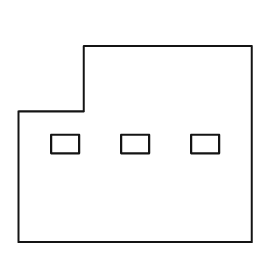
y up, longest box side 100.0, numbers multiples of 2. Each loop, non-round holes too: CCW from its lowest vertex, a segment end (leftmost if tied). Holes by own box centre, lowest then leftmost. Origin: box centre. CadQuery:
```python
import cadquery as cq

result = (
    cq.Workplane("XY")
    .moveTo(-50.0, -42.0)
    .lineTo(50.0, -42.0)
    .lineTo(50.0, 42.0)
    .lineTo(-22.0, 42.0)
    .lineTo(-22.0, 14.0)
    .lineTo(-50.0, 14.0)
    .close()
    .moveTo(-36.0, -4.0)
    .lineTo(-24.0, -4.0)
    .lineTo(-24.0, 4.0)
    .lineTo(-36.0, 4.0)
    .close()
    .moveTo(-6.0, -4.0)
    .lineTo(6.0, -4.0)
    .lineTo(6.0, 4.0)
    .lineTo(-6.0, 4.0)
    .close()
    .moveTo(24.0, -4.0)
    .lineTo(36.0, -4.0)
    .lineTo(36.0, 4.0)
    .lineTo(24.0, 4.0)
    .close()
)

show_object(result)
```